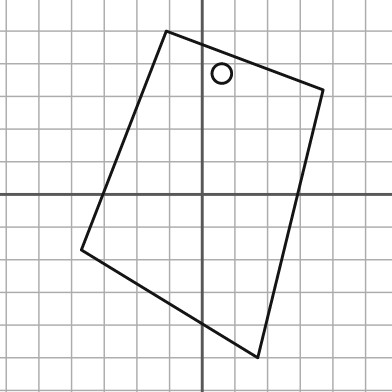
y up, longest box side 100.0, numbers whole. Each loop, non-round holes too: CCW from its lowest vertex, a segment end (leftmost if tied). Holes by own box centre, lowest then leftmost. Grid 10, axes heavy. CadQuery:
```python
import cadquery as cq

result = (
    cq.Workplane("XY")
    .moveTo(17.0, -50.0)
    .lineTo(37.0, 32.0)
    .lineTo(-11.0, 50.0)
    .lineTo(-37.0, -17.0)
    .close()
    .moveTo(6.0, 37.0)
    .circle(3.0)
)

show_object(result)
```